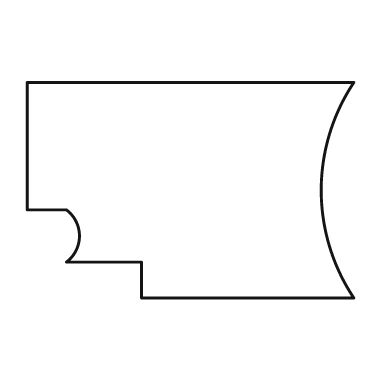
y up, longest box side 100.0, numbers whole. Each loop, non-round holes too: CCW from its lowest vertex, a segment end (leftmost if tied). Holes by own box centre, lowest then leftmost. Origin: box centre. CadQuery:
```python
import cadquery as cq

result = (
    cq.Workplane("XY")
    .moveTo(-15.0, -33.0)
    .lineTo(50.0, -33.0)
    .threePointArc((40.0, 0.0), (50.0, 33.0))
    .lineTo(-50.0, 33.0)
    .lineTo(-50.0, -6.0)
    .lineTo(-38.0, -6.0)
    .threePointArc((-34.0, -14.0), (-38.0, -22.0))
    .lineTo(-15.0, -22.0)
    .close()
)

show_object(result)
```